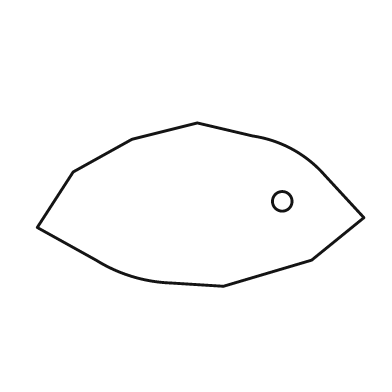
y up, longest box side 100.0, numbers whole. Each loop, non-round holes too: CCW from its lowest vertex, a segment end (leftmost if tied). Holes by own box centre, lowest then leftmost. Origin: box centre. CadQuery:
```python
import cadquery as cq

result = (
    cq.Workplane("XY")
    .moveTo(7.0, -25.0)
    .lineTo(34.0, -17.0)
    .lineTo(50.0, -4.0)
    .lineTo(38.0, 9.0)
    .threePointArc((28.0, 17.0), (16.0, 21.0))
    .lineTo(-1.0, 25.0)
    .lineTo(-21.0, 20.0)
    .lineTo(-39.0, 10.0)
    .lineTo(-50.0, -7.0)
    .lineTo(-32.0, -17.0)
    .threePointArc((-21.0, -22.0), (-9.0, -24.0))
    .close()
    .moveTo(25.0, 1.0)
    .circle(3.0)
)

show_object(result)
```